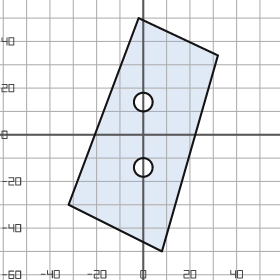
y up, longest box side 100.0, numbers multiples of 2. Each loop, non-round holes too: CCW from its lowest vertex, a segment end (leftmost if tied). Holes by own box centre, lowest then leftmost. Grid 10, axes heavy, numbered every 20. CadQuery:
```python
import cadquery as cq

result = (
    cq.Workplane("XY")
    .moveTo(8.0, -50.0)
    .lineTo(32.0, 34.0)
    .lineTo(-2.0, 50.0)
    .lineTo(-32.0, -30.0)
    .close()
    .moveTo(0.0, -14.0)
    .circle(4.0)
    .moveTo(0.0, 14.0)
    .circle(4.0)
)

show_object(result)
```